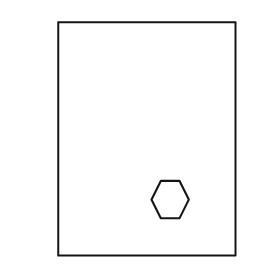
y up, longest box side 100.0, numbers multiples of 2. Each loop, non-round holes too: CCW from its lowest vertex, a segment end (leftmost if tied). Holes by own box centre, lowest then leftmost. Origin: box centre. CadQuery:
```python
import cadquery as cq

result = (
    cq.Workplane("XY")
    .moveTo(-38.0, -50.0)
    .lineTo(38.0, -50.0)
    .lineTo(38.0, 50.0)
    .lineTo(-38.0, 50.0)
    .close()
    .moveTo(6.0, -34.0)
    .lineTo(14.0, -34.0)
    .lineTo(18.0, -26.0)
    .lineTo(14.0, -18.0)
    .lineTo(6.0, -18.0)
    .lineTo(2.0, -26.0)
    .close()
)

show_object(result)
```